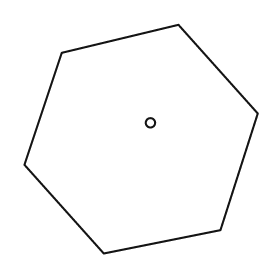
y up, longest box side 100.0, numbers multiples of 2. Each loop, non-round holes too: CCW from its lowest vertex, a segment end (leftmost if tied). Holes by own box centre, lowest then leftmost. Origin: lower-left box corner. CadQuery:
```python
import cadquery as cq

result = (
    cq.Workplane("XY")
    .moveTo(34.0, 0.0)
    .lineTo(84.0, 10.0)
    .lineTo(100.0, 60.0)
    .lineTo(66.0, 98.0)
    .lineTo(16.0, 86.0)
    .lineTo(0.0, 38.0)
    .close()
    .moveTo(54.0, 56.0)
    .circle(2.0)
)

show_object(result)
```